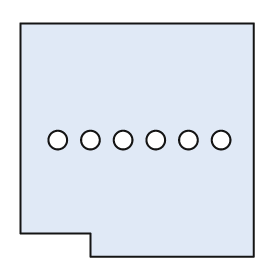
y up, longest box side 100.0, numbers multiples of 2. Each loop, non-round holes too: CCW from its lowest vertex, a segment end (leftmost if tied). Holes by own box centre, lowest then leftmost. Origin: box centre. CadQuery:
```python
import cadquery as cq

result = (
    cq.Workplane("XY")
    .moveTo(-20.0, -50.0)
    .lineTo(50.0, -50.0)
    .lineTo(50.0, 50.0)
    .lineTo(-50.0, 50.0)
    .lineTo(-50.0, -40.0)
    .lineTo(-20.0, -40.0)
    .close()
    .moveTo(-34.0, 0.0)
    .circle(4.0)
    .moveTo(-20.0, 0.0)
    .circle(4.0)
    .moveTo(-6.0, 0.0)
    .circle(4.0)
    .moveTo(8.0, 0.0)
    .circle(4.0)
    .moveTo(22.0, 0.0)
    .circle(4.0)
    .moveTo(36.0, 0.0)
    .circle(4.0)
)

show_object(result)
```